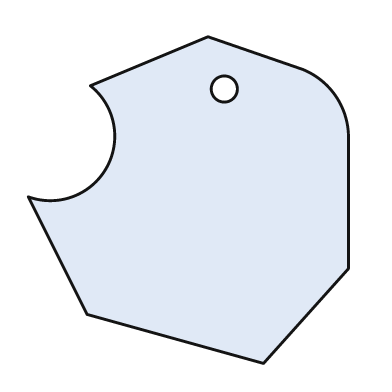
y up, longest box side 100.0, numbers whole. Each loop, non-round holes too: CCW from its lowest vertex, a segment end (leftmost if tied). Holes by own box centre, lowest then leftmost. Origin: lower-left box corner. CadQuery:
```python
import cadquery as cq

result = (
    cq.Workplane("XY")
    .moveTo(72.0, 0.0)
    .lineTo(98.0, 29.0)
    .lineTo(98.0, 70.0)
    .threePointArc((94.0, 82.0), (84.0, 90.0))
    .lineTo(55.0, 100.0)
    .lineTo(19.0, 85.0)
    .threePointArc((24.0, 60.0), (0.0, 51.0))
    .lineTo(18.0, 15.0)
    .close()
    .moveTo(60.0, 84.0)
    .circle(4.0)
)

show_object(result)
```